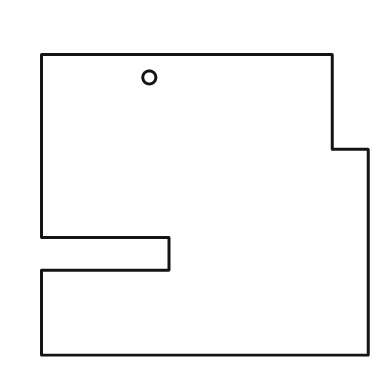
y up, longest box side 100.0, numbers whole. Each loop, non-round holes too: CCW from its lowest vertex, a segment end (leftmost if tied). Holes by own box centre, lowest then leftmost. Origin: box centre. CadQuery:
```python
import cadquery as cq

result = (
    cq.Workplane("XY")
    .moveTo(-50.0, -46.0)
    .lineTo(50.0, -46.0)
    .lineTo(50.0, 17.0)
    .lineTo(39.0, 17.0)
    .lineTo(39.0, 46.0)
    .lineTo(-50.0, 46.0)
    .lineTo(-50.0, -10.0)
    .lineTo(-11.0, -10.0)
    .lineTo(-11.0, -20.0)
    .lineTo(-50.0, -20.0)
    .close()
    .moveTo(-17.0, 39.0)
    .circle(2.0)
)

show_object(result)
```